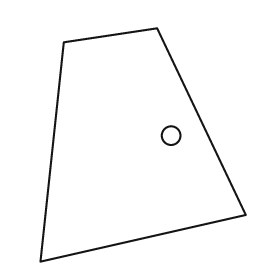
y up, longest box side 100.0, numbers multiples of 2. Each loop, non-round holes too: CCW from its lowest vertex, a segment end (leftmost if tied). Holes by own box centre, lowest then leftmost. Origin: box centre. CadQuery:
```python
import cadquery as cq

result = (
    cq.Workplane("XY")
    .moveTo(-44.0, -50.0)
    .lineTo(44.0, -30.0)
    .lineTo(6.0, 50.0)
    .lineTo(-34.0, 44.0)
    .close()
    .moveTo(12.0, 4.0)
    .circle(4.0)
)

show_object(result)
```